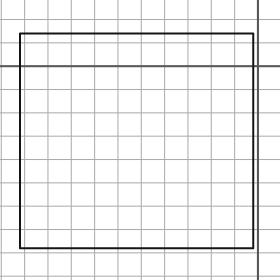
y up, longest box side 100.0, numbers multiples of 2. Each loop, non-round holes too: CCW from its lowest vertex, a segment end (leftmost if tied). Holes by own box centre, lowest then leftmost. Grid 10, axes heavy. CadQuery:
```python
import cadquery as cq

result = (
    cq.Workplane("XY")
    .moveTo(-102.0, -78.0)
    .lineTo(-2.0, -78.0)
    .lineTo(-2.0, 14.0)
    .lineTo(-102.0, 14.0)
    .close()
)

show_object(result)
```